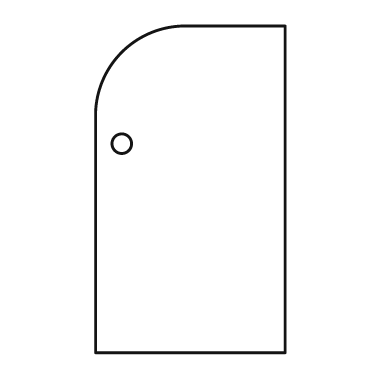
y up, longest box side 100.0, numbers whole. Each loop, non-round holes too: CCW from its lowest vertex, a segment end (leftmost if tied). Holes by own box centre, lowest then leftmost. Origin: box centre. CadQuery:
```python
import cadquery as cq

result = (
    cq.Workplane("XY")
    .moveTo(-29.0, -50.0)
    .lineTo(29.0, -50.0)
    .lineTo(29.0, 50.0)
    .lineTo(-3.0, 50.0)
    .threePointArc((-21.0, 42.0), (-29.0, 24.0))
    .close()
    .moveTo(-21.0, 14.0)
    .circle(3.0)
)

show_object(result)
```